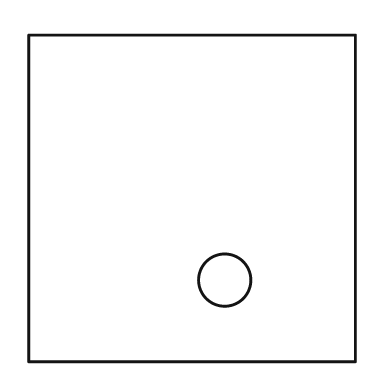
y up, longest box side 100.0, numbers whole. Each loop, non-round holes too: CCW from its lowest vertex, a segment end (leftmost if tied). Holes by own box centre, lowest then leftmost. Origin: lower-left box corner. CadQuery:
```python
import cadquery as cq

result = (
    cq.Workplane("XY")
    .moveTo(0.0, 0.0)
    .lineTo(100.0, 0.0)
    .lineTo(100.0, 100.0)
    .lineTo(0.0, 100.0)
    .close()
    .moveTo(60.0, 25.0)
    .circle(8.0)
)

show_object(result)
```